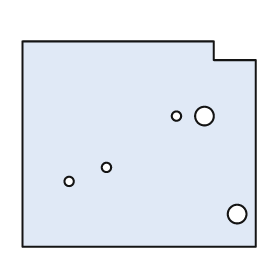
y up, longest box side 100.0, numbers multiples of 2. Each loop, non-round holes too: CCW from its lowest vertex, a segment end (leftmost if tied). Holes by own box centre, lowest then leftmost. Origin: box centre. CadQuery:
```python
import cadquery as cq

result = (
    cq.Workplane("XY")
    .moveTo(-50.0, -44.0)
    .lineTo(50.0, -44.0)
    .lineTo(50.0, 36.0)
    .lineTo(32.0, 36.0)
    .lineTo(32.0, 44.0)
    .lineTo(-50.0, 44.0)
    .close()
    .moveTo(42.0, -30.0)
    .circle(4.0)
    .moveTo(-30.0, -16.0)
    .circle(2.0)
    .moveTo(-14.0, -10.0)
    .circle(2.0)
    .moveTo(16.0, 12.0)
    .circle(2.0)
    .moveTo(28.0, 12.0)
    .circle(4.0)
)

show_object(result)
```